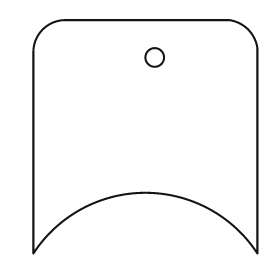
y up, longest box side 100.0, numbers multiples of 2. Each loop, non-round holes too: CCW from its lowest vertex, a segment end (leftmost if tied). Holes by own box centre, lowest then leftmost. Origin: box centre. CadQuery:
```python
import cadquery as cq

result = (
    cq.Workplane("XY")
    .moveTo(-48.0, -50.0)
    .threePointArc((0.0, -24.0), (48.0, -50.0))
    .lineTo(48.0, 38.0)
    .threePointArc((44.0, 46.0), (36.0, 50.0))
    .lineTo(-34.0, 50.0)
    .threePointArc((-44.0, 46.0), (-48.0, 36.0))
    .close()
    .moveTo(4.0, 34.0)
    .circle(4.0)
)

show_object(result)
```